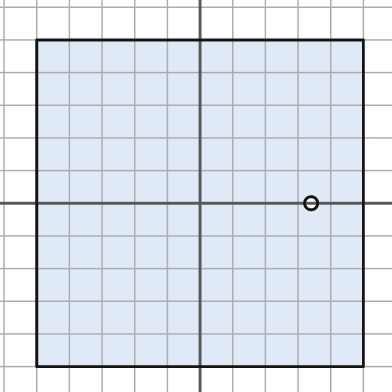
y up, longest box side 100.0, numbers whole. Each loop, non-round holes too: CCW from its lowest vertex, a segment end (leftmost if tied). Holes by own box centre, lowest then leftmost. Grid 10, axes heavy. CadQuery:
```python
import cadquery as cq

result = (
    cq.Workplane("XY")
    .moveTo(-50.0, -50.0)
    .lineTo(50.0, -50.0)
    .lineTo(50.0, 50.0)
    .lineTo(-50.0, 50.0)
    .close()
    .moveTo(34.0, 0.0)
    .circle(2.0)
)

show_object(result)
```